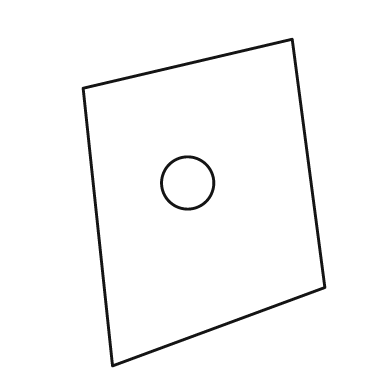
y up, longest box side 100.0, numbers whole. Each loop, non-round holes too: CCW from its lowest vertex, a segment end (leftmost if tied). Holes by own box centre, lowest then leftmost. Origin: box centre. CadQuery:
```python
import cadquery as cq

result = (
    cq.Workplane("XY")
    .moveTo(-28.0, -50.0)
    .lineTo(37.0, -26.0)
    .lineTo(27.0, 50.0)
    .lineTo(-37.0, 35.0)
    .close()
    .moveTo(-5.0, 6.0)
    .circle(8.0)
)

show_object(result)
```